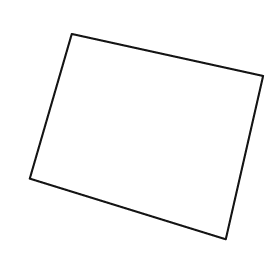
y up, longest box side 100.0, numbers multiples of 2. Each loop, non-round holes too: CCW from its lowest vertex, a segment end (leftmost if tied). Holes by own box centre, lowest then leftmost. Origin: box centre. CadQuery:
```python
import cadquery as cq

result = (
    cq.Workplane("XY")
    .moveTo(34.0, -44.0)
    .lineTo(50.0, 26.0)
    .lineTo(-32.0, 44.0)
    .lineTo(-50.0, -18.0)
    .close()
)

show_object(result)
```